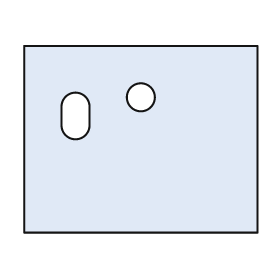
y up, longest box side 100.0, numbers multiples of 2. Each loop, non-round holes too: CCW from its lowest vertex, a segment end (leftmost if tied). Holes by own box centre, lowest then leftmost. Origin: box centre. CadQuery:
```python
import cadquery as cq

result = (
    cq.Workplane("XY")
    .moveTo(-50.0, -40.0)
    .lineTo(50.0, -40.0)
    .lineTo(50.0, 40.0)
    .lineTo(-50.0, 40.0)
    .close()
    .moveTo(-34.0, 6.0)
    .threePointArc((-28.0, 0.0), (-22.0, 6.0))
    .lineTo(-22.0, 14.0)
    .threePointArc((-28.0, 20.0), (-34.0, 14.0))
    .close()
    .moveTo(0.0, 18.0)
    .circle(6.0)
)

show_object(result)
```